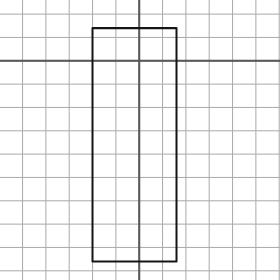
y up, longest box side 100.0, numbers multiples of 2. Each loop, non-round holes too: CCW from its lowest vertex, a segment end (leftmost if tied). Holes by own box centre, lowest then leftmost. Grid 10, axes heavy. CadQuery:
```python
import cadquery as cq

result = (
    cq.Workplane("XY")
    .moveTo(-20.0, -86.0)
    .lineTo(16.0, -86.0)
    .lineTo(16.0, 14.0)
    .lineTo(-20.0, 14.0)
    .close()
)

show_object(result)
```